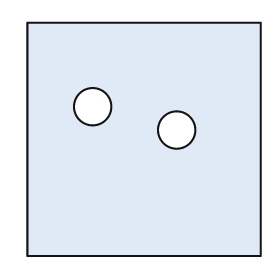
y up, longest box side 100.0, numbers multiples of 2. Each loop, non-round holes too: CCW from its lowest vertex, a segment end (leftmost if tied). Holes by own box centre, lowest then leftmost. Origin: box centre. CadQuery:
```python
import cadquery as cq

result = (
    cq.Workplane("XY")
    .moveTo(-50.0, -50.0)
    .lineTo(50.0, -50.0)
    .lineTo(50.0, 50.0)
    .lineTo(-50.0, 50.0)
    .close()
    .moveTo(14.0, 4.0)
    .circle(8.0)
    .moveTo(-22.0, 14.0)
    .circle(8.0)
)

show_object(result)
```